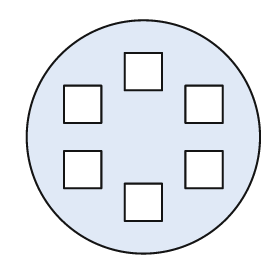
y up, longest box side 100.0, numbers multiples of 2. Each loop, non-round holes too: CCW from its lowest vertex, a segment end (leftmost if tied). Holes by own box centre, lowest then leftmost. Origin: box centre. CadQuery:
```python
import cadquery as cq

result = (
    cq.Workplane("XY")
    .moveTo(0.0, 0.0)
    .circle(50.0)
    .moveTo(-8.0, -36.0)
    .lineTo(8.0, -36.0)
    .lineTo(8.0, -20.0)
    .lineTo(-8.0, -20.0)
    .close()
    .moveTo(-34.0, -22.0)
    .lineTo(-18.0, -22.0)
    .lineTo(-18.0, -6.0)
    .lineTo(-34.0, -6.0)
    .close()
    .moveTo(18.0, -22.0)
    .lineTo(34.0, -22.0)
    .lineTo(34.0, -6.0)
    .lineTo(18.0, -6.0)
    .close()
    .moveTo(-34.0, 6.0)
    .lineTo(-18.0, 6.0)
    .lineTo(-18.0, 22.0)
    .lineTo(-34.0, 22.0)
    .close()
    .moveTo(18.0, 6.0)
    .lineTo(34.0, 6.0)
    .lineTo(34.0, 22.0)
    .lineTo(18.0, 22.0)
    .close()
    .moveTo(-8.0, 20.0)
    .lineTo(8.0, 20.0)
    .lineTo(8.0, 36.0)
    .lineTo(-8.0, 36.0)
    .close()
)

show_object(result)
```